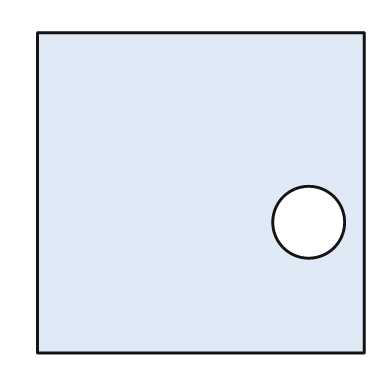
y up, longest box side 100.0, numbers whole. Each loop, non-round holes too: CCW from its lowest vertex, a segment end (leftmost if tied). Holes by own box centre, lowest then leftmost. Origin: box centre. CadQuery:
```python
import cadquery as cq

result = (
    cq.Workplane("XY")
    .moveTo(-50.0, -49.0)
    .lineTo(50.0, -49.0)
    .lineTo(50.0, 49.0)
    .lineTo(-50.0, 49.0)
    .close()
    .moveTo(33.0, -9.0)
    .circle(11.0)
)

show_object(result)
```